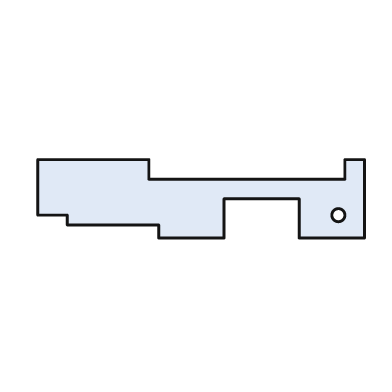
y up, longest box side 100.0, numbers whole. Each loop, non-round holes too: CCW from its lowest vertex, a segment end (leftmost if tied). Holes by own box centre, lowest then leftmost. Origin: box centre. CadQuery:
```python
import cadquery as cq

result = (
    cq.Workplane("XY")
    .moveTo(-13.0, -12.0)
    .lineTo(7.0, -12.0)
    .lineTo(7.0, 0.0)
    .lineTo(30.0, 0.0)
    .lineTo(30.0, -12.0)
    .lineTo(50.0, -12.0)
    .lineTo(50.0, 12.0)
    .lineTo(44.0, 12.0)
    .lineTo(44.0, 6.0)
    .lineTo(-16.0, 6.0)
    .lineTo(-16.0, 12.0)
    .lineTo(-50.0, 12.0)
    .lineTo(-50.0, -5.0)
    .lineTo(-41.0, -5.0)
    .lineTo(-41.0, -8.0)
    .lineTo(-13.0, -8.0)
    .close()
    .moveTo(42.0, -5.0)
    .circle(2.0)
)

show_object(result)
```